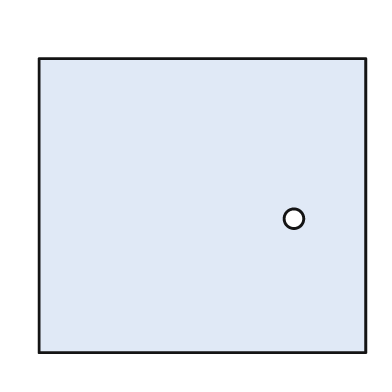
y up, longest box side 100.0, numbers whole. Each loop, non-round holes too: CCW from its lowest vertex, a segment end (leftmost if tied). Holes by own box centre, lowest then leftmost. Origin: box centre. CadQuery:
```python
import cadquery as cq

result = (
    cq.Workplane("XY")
    .moveTo(-50.0, -45.0)
    .lineTo(50.0, -45.0)
    .lineTo(50.0, 45.0)
    .lineTo(-50.0, 45.0)
    .close()
    .moveTo(28.0, -4.0)
    .circle(3.0)
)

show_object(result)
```